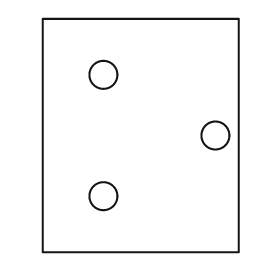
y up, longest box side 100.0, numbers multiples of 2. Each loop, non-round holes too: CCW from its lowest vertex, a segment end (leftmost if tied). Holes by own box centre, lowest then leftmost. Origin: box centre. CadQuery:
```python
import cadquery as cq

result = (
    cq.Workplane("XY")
    .moveTo(-42.0, -50.0)
    .lineTo(42.0, -50.0)
    .lineTo(42.0, 50.0)
    .lineTo(-42.0, 50.0)
    .close()
    .moveTo(-16.0, -26.0)
    .circle(6.0)
    .moveTo(32.0, 0.0)
    .circle(6.0)
    .moveTo(-16.0, 26.0)
    .circle(6.0)
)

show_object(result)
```